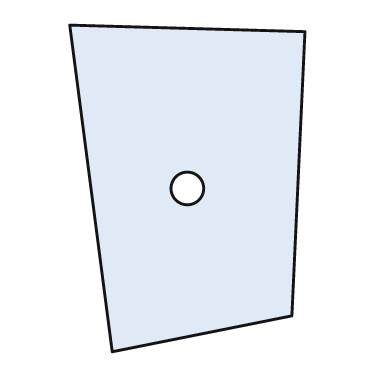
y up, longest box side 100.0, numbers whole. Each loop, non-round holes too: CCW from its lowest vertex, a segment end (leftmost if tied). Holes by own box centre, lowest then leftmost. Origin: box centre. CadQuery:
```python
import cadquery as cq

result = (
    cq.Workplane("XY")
    .moveTo(-23.0, -50.0)
    .lineTo(32.0, -39.0)
    .lineTo(36.0, 48.0)
    .lineTo(-36.0, 50.0)
    .close()
    .moveTo(0.0, 0.0)
    .circle(5.0)
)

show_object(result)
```